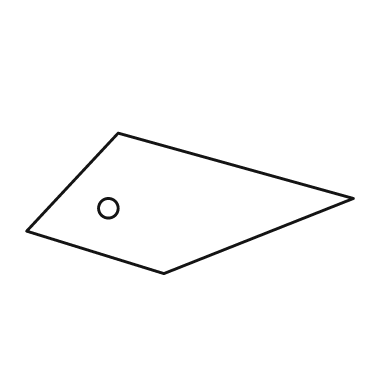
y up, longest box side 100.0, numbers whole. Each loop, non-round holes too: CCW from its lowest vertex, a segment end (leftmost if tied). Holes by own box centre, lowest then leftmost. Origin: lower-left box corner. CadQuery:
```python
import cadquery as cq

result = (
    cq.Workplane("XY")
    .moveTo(42.0, 0.0)
    .lineTo(100.0, 23.0)
    .lineTo(28.0, 43.0)
    .lineTo(0.0, 13.0)
    .close()
    .moveTo(25.0, 20.0)
    .circle(3.0)
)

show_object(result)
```